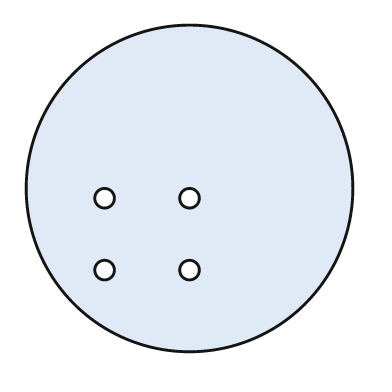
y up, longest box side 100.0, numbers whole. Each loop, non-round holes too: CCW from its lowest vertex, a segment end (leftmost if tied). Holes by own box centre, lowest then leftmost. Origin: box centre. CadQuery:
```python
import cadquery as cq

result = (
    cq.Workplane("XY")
    .moveTo(0.0, 0.0)
    .circle(50.0)
    .moveTo(-26.0, -25.0)
    .circle(3.0)
    .moveTo(0.0, -25.0)
    .circle(3.0)
    .moveTo(-26.0, -3.0)
    .circle(3.0)
    .moveTo(0.0, -3.0)
    .circle(3.0)
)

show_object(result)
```